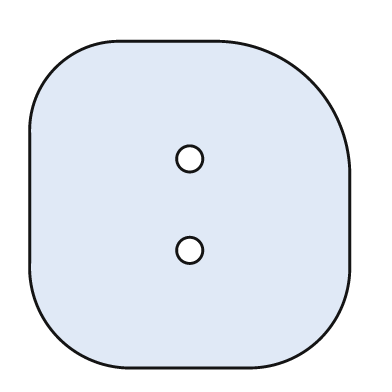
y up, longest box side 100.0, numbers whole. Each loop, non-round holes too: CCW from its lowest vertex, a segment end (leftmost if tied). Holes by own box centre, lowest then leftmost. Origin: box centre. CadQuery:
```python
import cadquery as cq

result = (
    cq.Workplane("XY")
    .moveTo(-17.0, -50.0)
    .lineTo(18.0, -50.0)
    .threePointArc((40.0, -41.0), (49.0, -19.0))
    .lineTo(49.0, 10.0)
    .threePointArc((37.0, 38.0), (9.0, 50.0))
    .lineTo(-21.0, 50.0)
    .threePointArc((-41.0, 42.0), (-49.0, 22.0))
    .lineTo(-49.0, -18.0)
    .threePointArc((-40.0, -41.0), (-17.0, -50.0))
    .close()
    .moveTo(0.0, -14.0)
    .circle(4.0)
    .moveTo(0.0, 14.0)
    .circle(4.0)
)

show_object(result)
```